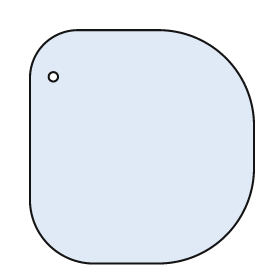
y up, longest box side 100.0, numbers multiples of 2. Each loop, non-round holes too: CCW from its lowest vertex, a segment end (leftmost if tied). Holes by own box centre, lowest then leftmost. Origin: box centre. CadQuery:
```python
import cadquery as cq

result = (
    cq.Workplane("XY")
    .moveTo(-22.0, -50.0)
    .lineTo(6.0, -50.0)
    .threePointArc((36.0, -38.0), (48.0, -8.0))
    .lineTo(48.0, 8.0)
    .threePointArc((36.0, 38.0), (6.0, 50.0))
    .lineTo(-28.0, 50.0)
    .threePointArc((-42.0, 44.0), (-48.0, 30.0))
    .lineTo(-48.0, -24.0)
    .threePointArc((-40.0, -42.0), (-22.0, -50.0))
    .close()
    .moveTo(-38.0, 30.0)
    .circle(2.0)
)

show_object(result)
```